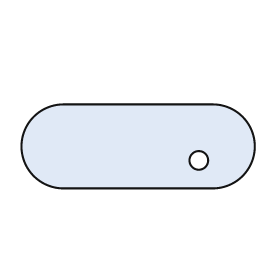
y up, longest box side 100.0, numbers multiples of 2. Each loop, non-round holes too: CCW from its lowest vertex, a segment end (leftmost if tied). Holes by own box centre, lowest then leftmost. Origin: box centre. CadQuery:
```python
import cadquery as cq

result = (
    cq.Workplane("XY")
    .moveTo(-32.0, -18.0)
    .lineTo(32.0, -18.0)
    .threePointArc((50.0, 0.0), (32.0, 18.0))
    .lineTo(-32.0, 18.0)
    .threePointArc((-50.0, 0.0), (-32.0, -18.0))
    .close()
    .moveTo(26.0, -6.0)
    .circle(4.0)
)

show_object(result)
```